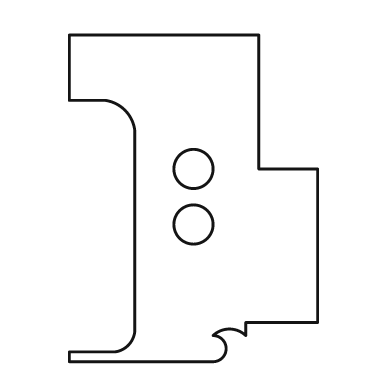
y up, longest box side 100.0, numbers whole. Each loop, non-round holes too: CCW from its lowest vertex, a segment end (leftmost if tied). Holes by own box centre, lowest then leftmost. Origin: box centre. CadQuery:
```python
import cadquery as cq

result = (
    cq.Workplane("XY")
    .moveTo(-38.0, -50.0)
    .lineTo(6.0, -50.0)
    .threePointArc((10.0, -46.0), (6.0, -42.0))
    .threePointArc((11.0, -40.0), (16.0, -42.0))
    .lineTo(16.0, -38.0)
    .lineTo(38.0, -38.0)
    .lineTo(38.0, 9.0)
    .lineTo(20.0, 9.0)
    .lineTo(20.0, 50.0)
    .lineTo(-38.0, 50.0)
    .lineTo(-38.0, 30.0)
    .lineTo(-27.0, 30.0)
    .threePointArc((-21.0, 27.0), (-18.0, 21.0))
    .lineTo(-18.0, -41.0)
    .threePointArc((-20.0, -45.0), (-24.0, -47.0))
    .lineTo(-38.0, -47.0)
    .close()
    .moveTo(0.0, -8.0)
    .circle(6.0)
    .moveTo(0.0, 9.0)
    .circle(6.0)
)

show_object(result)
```